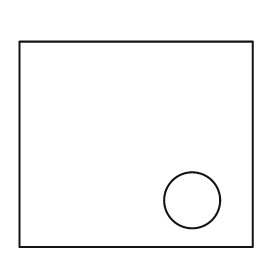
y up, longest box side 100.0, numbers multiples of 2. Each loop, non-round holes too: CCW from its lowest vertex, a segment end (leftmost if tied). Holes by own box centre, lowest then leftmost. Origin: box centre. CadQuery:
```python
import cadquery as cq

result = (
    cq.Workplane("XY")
    .moveTo(-50.0, -44.0)
    .lineTo(50.0, -44.0)
    .lineTo(50.0, 44.0)
    .lineTo(-50.0, 44.0)
    .close()
    .moveTo(24.0, -24.0)
    .circle(12.0)
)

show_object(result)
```